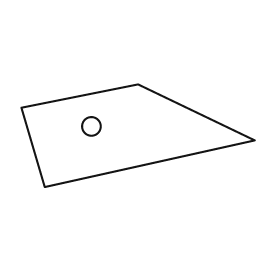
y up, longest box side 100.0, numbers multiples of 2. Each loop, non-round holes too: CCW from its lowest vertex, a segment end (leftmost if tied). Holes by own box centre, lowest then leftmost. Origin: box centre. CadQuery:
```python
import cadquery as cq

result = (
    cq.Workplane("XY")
    .moveTo(-40.0, -22.0)
    .lineTo(50.0, -2.0)
    .lineTo(0.0, 22.0)
    .lineTo(-50.0, 12.0)
    .close()
    .moveTo(-20.0, 4.0)
    .circle(4.0)
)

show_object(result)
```